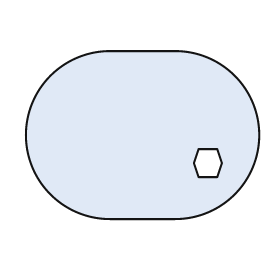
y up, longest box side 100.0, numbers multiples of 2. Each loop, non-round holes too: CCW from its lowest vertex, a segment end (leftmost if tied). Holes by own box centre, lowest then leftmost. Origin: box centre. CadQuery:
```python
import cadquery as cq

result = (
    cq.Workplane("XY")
    .moveTo(-14.0, -36.0)
    .lineTo(14.0, -36.0)
    .threePointArc((50.0, 0.0), (14.0, 36.0))
    .lineTo(-14.0, 36.0)
    .threePointArc((-50.0, 0.0), (-14.0, -36.0))
    .close()
    .moveTo(24.0, -18.0)
    .lineTo(32.0, -18.0)
    .lineTo(34.0, -12.0)
    .lineTo(32.0, -6.0)
    .lineTo(24.0, -6.0)
    .lineTo(22.0, -12.0)
    .close()
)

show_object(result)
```